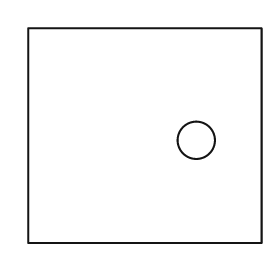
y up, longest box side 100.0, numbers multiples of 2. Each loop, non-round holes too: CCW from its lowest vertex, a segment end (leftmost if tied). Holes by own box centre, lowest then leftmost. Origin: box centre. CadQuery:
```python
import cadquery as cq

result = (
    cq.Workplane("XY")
    .moveTo(-50.0, -46.0)
    .lineTo(50.0, -46.0)
    .lineTo(50.0, 46.0)
    .lineTo(-50.0, 46.0)
    .close()
    .moveTo(22.0, -2.0)
    .circle(8.0)
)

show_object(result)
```